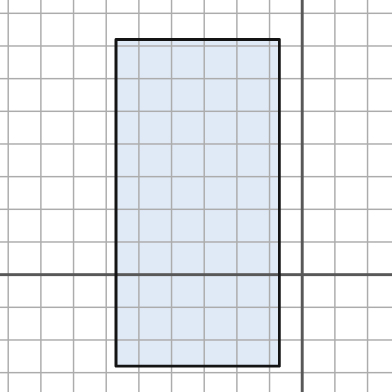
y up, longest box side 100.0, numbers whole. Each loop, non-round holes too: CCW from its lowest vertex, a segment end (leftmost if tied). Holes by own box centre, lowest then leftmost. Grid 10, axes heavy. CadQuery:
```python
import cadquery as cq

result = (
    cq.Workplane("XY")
    .moveTo(-57.0, -28.0)
    .lineTo(-7.0, -28.0)
    .lineTo(-7.0, 72.0)
    .lineTo(-57.0, 72.0)
    .close()
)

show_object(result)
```